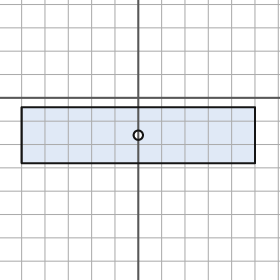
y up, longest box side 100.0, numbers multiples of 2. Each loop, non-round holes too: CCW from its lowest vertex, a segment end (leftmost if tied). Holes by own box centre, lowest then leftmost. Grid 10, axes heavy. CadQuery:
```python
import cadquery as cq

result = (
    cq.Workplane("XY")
    .moveTo(-50.0, -28.0)
    .lineTo(50.0, -28.0)
    .lineTo(50.0, -4.0)
    .lineTo(-50.0, -4.0)
    .close()
    .moveTo(0.0, -16.0)
    .circle(2.0)
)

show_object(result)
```